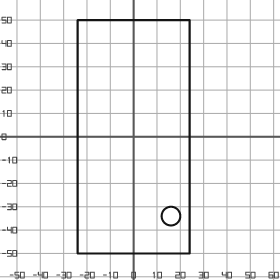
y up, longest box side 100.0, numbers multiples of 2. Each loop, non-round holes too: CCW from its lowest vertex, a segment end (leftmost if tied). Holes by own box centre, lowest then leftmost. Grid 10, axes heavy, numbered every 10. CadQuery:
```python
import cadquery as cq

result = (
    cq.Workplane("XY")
    .moveTo(-24.0, -50.0)
    .lineTo(24.0, -50.0)
    .lineTo(24.0, 50.0)
    .lineTo(-24.0, 50.0)
    .close()
    .moveTo(16.0, -34.0)
    .circle(4.0)
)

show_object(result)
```